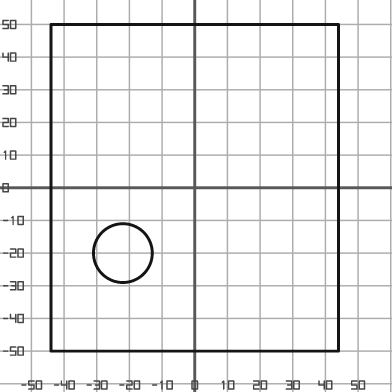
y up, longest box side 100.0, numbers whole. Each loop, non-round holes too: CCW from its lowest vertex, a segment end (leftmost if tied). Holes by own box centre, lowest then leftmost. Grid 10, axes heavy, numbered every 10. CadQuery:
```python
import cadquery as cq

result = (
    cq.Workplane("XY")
    .moveTo(-44.0, -50.0)
    .lineTo(44.0, -50.0)
    .lineTo(44.0, 50.0)
    .lineTo(-44.0, 50.0)
    .close()
    .moveTo(-22.0, -20.0)
    .circle(9.0)
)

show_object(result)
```